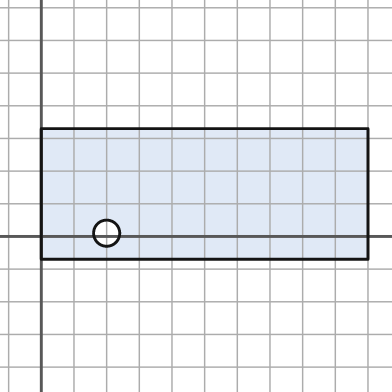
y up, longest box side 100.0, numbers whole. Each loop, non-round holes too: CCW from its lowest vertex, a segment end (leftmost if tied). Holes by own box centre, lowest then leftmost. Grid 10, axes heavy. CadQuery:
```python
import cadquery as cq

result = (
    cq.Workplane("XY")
    .moveTo(0.0, -7.0)
    .lineTo(100.0, -7.0)
    .lineTo(100.0, 33.0)
    .lineTo(0.0, 33.0)
    .close()
    .moveTo(20.0, 1.0)
    .circle(4.0)
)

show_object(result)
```